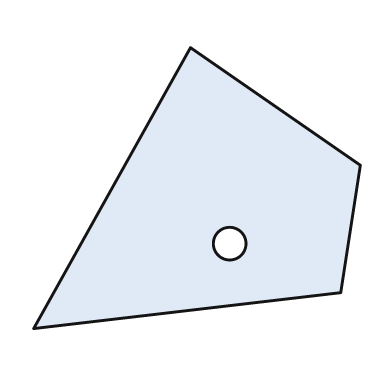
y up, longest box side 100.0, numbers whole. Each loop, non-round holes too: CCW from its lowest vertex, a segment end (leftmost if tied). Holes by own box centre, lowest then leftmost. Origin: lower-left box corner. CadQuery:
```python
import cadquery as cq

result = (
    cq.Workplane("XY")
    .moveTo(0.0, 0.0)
    .lineTo(94.0, 11.0)
    .lineTo(100.0, 50.0)
    .lineTo(48.0, 86.0)
    .close()
    .moveTo(60.0, 26.0)
    .circle(5.0)
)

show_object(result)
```